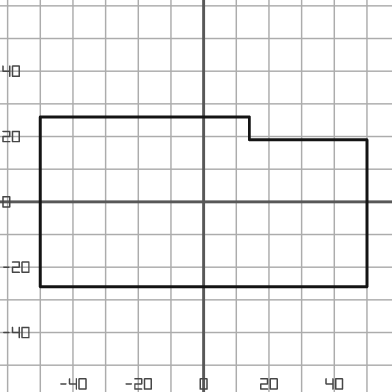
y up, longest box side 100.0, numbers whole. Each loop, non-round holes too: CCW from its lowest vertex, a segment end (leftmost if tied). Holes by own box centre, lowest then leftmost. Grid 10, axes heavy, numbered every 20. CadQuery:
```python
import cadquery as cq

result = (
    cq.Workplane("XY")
    .moveTo(-50.0, -26.0)
    .lineTo(50.0, -26.0)
    .lineTo(50.0, 19.0)
    .lineTo(14.0, 19.0)
    .lineTo(14.0, 26.0)
    .lineTo(-50.0, 26.0)
    .close()
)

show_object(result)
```